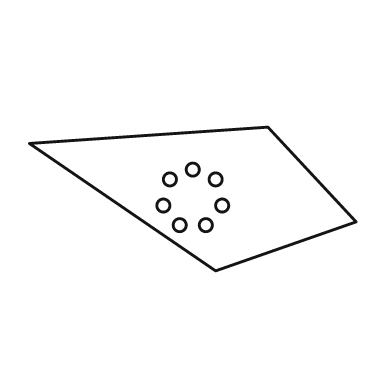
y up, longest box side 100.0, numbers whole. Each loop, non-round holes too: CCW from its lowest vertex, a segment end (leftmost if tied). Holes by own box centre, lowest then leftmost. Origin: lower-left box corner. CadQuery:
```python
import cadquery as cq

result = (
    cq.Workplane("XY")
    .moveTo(57.0, 0.0)
    .lineTo(100.0, 15.0)
    .lineTo(73.0, 44.0)
    .lineTo(0.0, 39.0)
    .close()
    .moveTo(46.0, 14.0)
    .circle(2.0)
    .moveTo(54.0, 14.0)
    .circle(2.0)
    .moveTo(41.0, 20.0)
    .circle(2.0)
    .moveTo(59.0, 20.0)
    .circle(2.0)
    .moveTo(43.0, 28.0)
    .circle(2.0)
    .moveTo(57.0, 28.0)
    .circle(2.0)
    .moveTo(50.0, 31.0)
    .circle(2.0)
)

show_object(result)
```